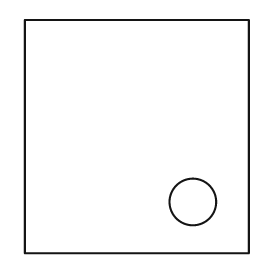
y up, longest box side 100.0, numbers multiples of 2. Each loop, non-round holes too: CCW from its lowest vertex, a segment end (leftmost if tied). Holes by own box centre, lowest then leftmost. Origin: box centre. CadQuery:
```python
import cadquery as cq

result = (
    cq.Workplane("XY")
    .moveTo(-48.0, -50.0)
    .lineTo(48.0, -50.0)
    .lineTo(48.0, 50.0)
    .lineTo(-48.0, 50.0)
    .close()
    .moveTo(24.0, -28.0)
    .circle(10.0)
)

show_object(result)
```